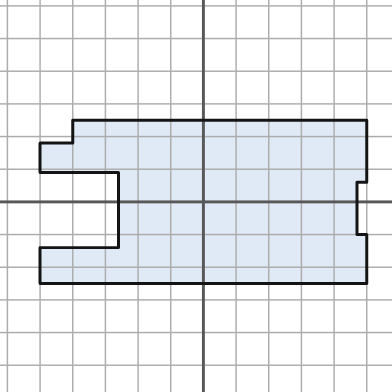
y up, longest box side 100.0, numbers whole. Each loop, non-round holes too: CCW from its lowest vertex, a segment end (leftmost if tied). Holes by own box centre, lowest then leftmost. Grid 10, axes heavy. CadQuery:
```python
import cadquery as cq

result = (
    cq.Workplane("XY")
    .moveTo(-50.0, -25.0)
    .lineTo(50.0, -25.0)
    .lineTo(50.0, -10.0)
    .lineTo(47.0, -10.0)
    .lineTo(47.0, 6.0)
    .lineTo(50.0, 6.0)
    .lineTo(50.0, 25.0)
    .lineTo(-40.0, 25.0)
    .lineTo(-40.0, 18.0)
    .lineTo(-50.0, 18.0)
    .lineTo(-50.0, 9.0)
    .lineTo(-26.0, 9.0)
    .lineTo(-26.0, -14.0)
    .lineTo(-50.0, -14.0)
    .close()
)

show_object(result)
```